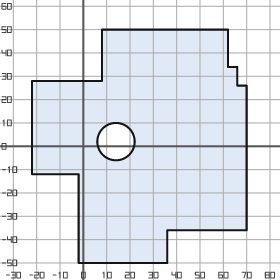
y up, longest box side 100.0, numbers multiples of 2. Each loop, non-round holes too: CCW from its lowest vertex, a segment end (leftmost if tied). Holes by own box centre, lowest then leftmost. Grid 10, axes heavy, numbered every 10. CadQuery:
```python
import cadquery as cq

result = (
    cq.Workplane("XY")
    .moveTo(-2.0, -50.0)
    .lineTo(36.0, -50.0)
    .lineTo(36.0, -36.0)
    .lineTo(70.0, -36.0)
    .lineTo(70.0, 26.0)
    .lineTo(66.0, 26.0)
    .lineTo(66.0, 34.0)
    .lineTo(62.0, 34.0)
    .lineTo(62.0, 50.0)
    .lineTo(8.0, 50.0)
    .lineTo(8.0, 28.0)
    .lineTo(-22.0, 28.0)
    .lineTo(-22.0, -12.0)
    .lineTo(-2.0, -12.0)
    .close()
    .moveTo(14.0, 2.0)
    .circle(8.0)
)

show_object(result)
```